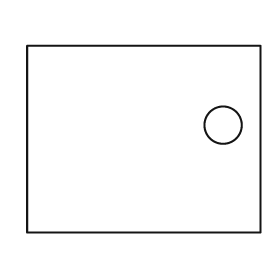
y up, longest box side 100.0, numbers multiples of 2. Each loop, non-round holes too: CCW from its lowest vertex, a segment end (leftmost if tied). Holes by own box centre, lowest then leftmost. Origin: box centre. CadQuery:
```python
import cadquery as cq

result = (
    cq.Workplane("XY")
    .moveTo(-50.0, -40.0)
    .lineTo(50.0, -40.0)
    .lineTo(50.0, 40.0)
    .lineTo(-50.0, 40.0)
    .close()
    .moveTo(34.0, 6.0)
    .circle(8.0)
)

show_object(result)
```